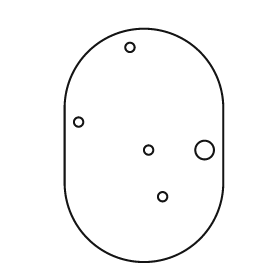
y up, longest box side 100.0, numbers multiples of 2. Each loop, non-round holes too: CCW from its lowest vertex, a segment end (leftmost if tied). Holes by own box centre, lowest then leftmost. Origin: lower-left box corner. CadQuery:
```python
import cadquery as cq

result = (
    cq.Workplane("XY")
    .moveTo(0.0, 34.0)
    .threePointArc((34.0, 0.0), (68.0, 34.0))
    .lineTo(68.0, 66.0)
    .threePointArc((34.0, 100.0), (0.0, 66.0))
    .close()
    .moveTo(42.0, 28.0)
    .circle(2.0)
    .moveTo(36.0, 48.0)
    .circle(2.0)
    .moveTo(60.0, 48.0)
    .circle(4.0)
    .moveTo(6.0, 60.0)
    .circle(2.0)
    .moveTo(28.0, 92.0)
    .circle(2.0)
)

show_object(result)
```